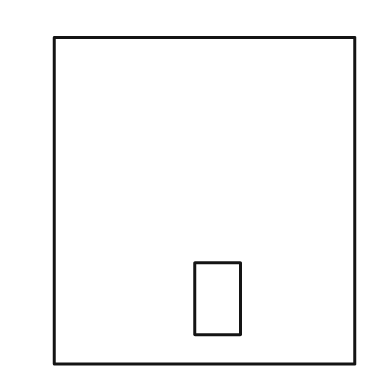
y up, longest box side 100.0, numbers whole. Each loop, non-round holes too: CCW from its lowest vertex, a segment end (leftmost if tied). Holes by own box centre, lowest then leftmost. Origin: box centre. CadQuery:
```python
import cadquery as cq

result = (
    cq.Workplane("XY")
    .moveTo(-46.0, -50.0)
    .lineTo(46.0, -50.0)
    .lineTo(46.0, 50.0)
    .lineTo(-46.0, 50.0)
    .close()
    .moveTo(-3.0, -41.0)
    .lineTo(11.0, -41.0)
    .lineTo(11.0, -19.0)
    .lineTo(-3.0, -19.0)
    .close()
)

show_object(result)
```